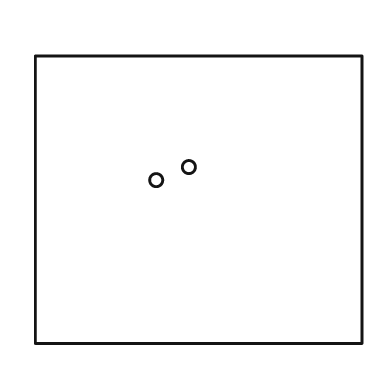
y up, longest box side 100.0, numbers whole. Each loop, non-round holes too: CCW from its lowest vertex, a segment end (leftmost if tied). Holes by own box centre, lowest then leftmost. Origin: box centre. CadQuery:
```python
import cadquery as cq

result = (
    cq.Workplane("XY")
    .moveTo(-50.0, -44.0)
    .lineTo(50.0, -44.0)
    .lineTo(50.0, 44.0)
    .lineTo(-50.0, 44.0)
    .close()
    .moveTo(-13.0, 6.0)
    .circle(2.0)
    .moveTo(-3.0, 10.0)
    .circle(2.0)
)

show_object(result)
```